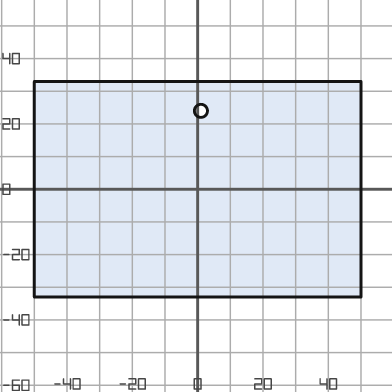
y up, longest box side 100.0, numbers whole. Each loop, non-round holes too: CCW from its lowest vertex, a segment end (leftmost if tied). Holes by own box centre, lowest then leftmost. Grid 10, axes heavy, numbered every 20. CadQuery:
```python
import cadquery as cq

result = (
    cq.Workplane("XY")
    .moveTo(-50.0, -33.0)
    .lineTo(50.0, -33.0)
    .lineTo(50.0, 33.0)
    .lineTo(-50.0, 33.0)
    .close()
    .moveTo(1.0, 24.0)
    .circle(2.0)
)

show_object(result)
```